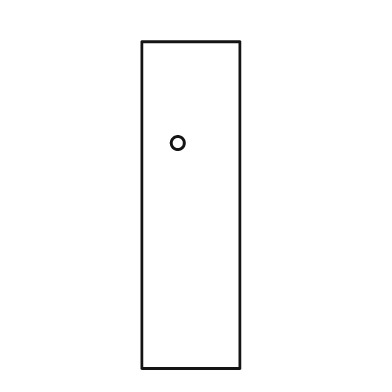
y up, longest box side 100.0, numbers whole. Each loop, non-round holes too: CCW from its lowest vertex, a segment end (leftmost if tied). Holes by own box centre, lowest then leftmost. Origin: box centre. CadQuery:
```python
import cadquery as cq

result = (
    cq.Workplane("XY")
    .moveTo(-15.0, -50.0)
    .lineTo(15.0, -50.0)
    .lineTo(15.0, 50.0)
    .lineTo(-15.0, 50.0)
    .close()
    .moveTo(-4.0, 19.0)
    .circle(2.0)
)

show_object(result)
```